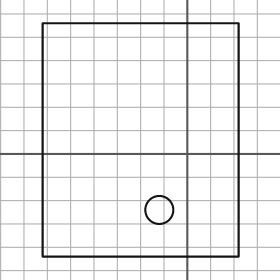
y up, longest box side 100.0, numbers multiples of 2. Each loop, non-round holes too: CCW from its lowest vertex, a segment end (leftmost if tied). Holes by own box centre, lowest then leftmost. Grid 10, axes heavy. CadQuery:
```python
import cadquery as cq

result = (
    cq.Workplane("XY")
    .moveTo(-62.0, -44.0)
    .lineTo(22.0, -44.0)
    .lineTo(22.0, 56.0)
    .lineTo(-62.0, 56.0)
    .close()
    .moveTo(-12.0, -24.0)
    .circle(6.0)
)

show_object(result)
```